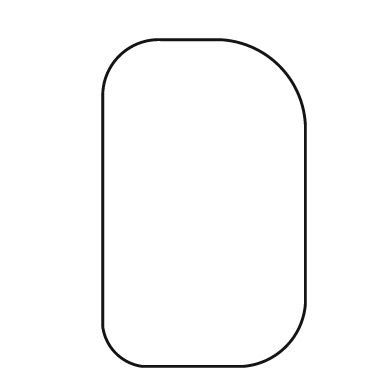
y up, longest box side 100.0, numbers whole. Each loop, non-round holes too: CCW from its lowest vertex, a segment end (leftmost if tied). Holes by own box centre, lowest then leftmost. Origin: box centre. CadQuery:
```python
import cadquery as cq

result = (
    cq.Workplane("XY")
    .moveTo(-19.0, -50.0)
    .lineTo(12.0, -50.0)
    .threePointArc((25.0, -44.0), (31.0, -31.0))
    .lineTo(31.0, 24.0)
    .threePointArc((23.0, 42.0), (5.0, 50.0))
    .lineTo(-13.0, 50.0)
    .threePointArc((-26.0, 45.0), (-31.0, 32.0))
    .lineTo(-31.0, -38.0)
    .threePointArc((-27.0, -46.0), (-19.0, -50.0))
    .close()
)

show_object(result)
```